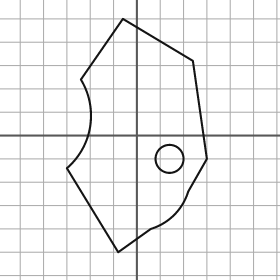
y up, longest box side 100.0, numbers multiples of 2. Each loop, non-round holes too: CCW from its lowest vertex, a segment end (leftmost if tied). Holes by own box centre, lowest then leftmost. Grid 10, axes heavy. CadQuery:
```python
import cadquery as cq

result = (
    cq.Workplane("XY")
    .moveTo(-8.0, -50.0)
    .lineTo(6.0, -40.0)
    .threePointArc((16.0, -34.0), (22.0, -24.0))
    .lineTo(30.0, -10.0)
    .lineTo(24.0, 32.0)
    .lineTo(-6.0, 50.0)
    .lineTo(-24.0, 24.0)
    .threePointArc((-20.0, 4.0), (-30.0, -14.0))
    .close()
    .moveTo(14.0, -10.0)
    .circle(6.0)
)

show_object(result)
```